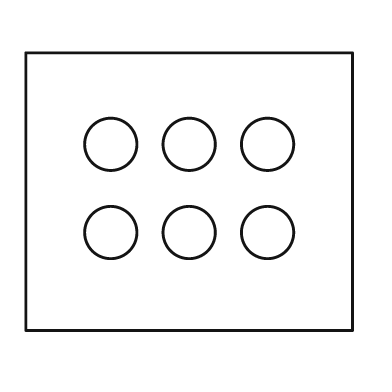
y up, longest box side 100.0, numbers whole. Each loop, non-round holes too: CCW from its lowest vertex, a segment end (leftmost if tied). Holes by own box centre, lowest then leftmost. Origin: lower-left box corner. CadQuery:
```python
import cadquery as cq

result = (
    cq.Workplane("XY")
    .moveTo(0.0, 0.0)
    .lineTo(100.0, 0.0)
    .lineTo(100.0, 85.0)
    .lineTo(0.0, 85.0)
    .close()
    .moveTo(26.0, 30.0)
    .circle(8.0)
    .moveTo(50.0, 30.0)
    .circle(8.0)
    .moveTo(74.0, 30.0)
    .circle(8.0)
    .moveTo(26.0, 57.0)
    .circle(8.0)
    .moveTo(50.0, 57.0)
    .circle(8.0)
    .moveTo(74.0, 57.0)
    .circle(8.0)
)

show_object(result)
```